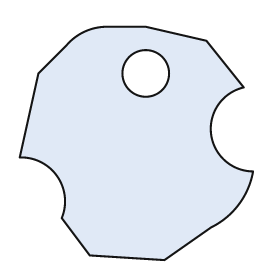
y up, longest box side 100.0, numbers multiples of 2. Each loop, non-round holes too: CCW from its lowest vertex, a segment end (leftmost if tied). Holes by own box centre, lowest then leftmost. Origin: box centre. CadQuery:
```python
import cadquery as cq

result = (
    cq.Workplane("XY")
    .moveTo(12.0, -50.0)
    .lineTo(32.0, -36.0)
    .threePointArc((44.0, -26.0), (50.0, -12.0))
    .threePointArc((32.0, 4.0), (46.0, 24.0))
    .lineTo(30.0, 44.0)
    .lineTo(4.0, 50.0)
    .lineTo(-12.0, 50.0)
    .threePointArc((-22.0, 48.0), (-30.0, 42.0))
    .lineTo(-42.0, 30.0)
    .lineTo(-50.0, -6.0)
    .threePointArc((-34.0, -14.0), (-32.0, -32.0))
    .lineTo(-20.0, -48.0)
    .close()
    .moveTo(4.0, 30.0)
    .circle(10.0)
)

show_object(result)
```